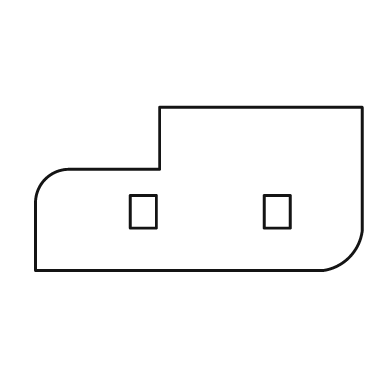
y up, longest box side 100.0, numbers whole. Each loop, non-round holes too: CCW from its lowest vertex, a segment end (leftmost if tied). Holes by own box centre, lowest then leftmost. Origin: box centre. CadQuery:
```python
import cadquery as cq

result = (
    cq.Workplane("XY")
    .moveTo(-50.0, -25.0)
    .lineTo(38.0, -25.0)
    .threePointArc((46.0, -21.0), (50.0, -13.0))
    .lineTo(50.0, 25.0)
    .lineTo(-12.0, 25.0)
    .lineTo(-12.0, 6.0)
    .lineTo(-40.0, 6.0)
    .threePointArc((-47.0, 3.0), (-50.0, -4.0))
    .close()
    .moveTo(-21.0, -12.0)
    .lineTo(-13.0, -12.0)
    .lineTo(-13.0, -2.0)
    .lineTo(-21.0, -2.0)
    .close()
    .moveTo(20.0, -12.0)
    .lineTo(28.0, -12.0)
    .lineTo(28.0, -2.0)
    .lineTo(20.0, -2.0)
    .close()
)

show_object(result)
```